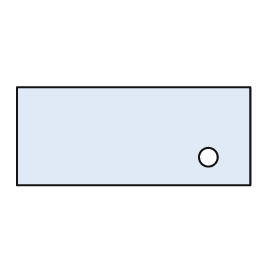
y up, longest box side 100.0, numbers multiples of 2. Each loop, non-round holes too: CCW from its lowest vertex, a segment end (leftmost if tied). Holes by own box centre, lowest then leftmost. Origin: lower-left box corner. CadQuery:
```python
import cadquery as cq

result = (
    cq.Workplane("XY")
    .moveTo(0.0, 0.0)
    .lineTo(100.0, 0.0)
    .lineTo(100.0, 42.0)
    .lineTo(0.0, 42.0)
    .close()
    .moveTo(82.0, 12.0)
    .circle(4.0)
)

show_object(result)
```